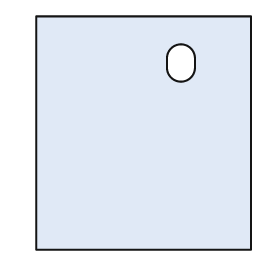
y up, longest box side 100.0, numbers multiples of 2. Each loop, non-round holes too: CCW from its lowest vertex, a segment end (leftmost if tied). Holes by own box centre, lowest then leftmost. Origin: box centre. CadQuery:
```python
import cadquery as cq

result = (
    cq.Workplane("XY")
    .moveTo(-46.0, -50.0)
    .lineTo(46.0, -50.0)
    .lineTo(46.0, 50.0)
    .lineTo(-46.0, 50.0)
    .close()
    .moveTo(10.0, 28.0)
    .threePointArc((16.0, 22.0), (22.0, 28.0))
    .lineTo(22.0, 32.0)
    .threePointArc((16.0, 38.0), (10.0, 32.0))
    .close()
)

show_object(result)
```